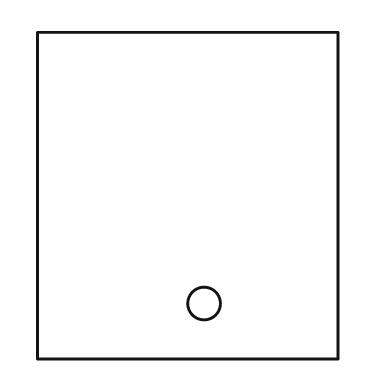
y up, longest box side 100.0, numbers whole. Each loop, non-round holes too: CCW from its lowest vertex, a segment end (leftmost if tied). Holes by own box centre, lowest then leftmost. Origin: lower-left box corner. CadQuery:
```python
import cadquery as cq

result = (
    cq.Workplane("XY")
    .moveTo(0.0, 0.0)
    .lineTo(92.0, 0.0)
    .lineTo(92.0, 100.0)
    .lineTo(0.0, 100.0)
    .close()
    .moveTo(51.0, 17.0)
    .circle(5.0)
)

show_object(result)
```